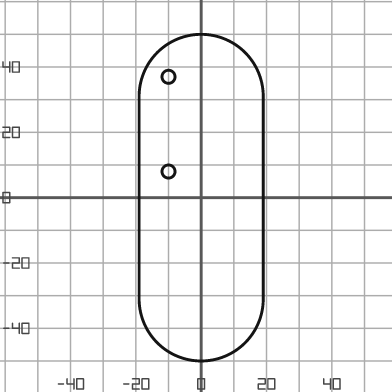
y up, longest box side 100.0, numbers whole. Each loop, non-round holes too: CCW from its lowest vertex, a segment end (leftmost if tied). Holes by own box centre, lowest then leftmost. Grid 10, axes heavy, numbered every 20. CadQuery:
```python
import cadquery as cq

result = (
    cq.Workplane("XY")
    .moveTo(-19.0, -31.0)
    .threePointArc((0.0, -50.0), (19.0, -31.0))
    .lineTo(19.0, 31.0)
    .threePointArc((0.0, 50.0), (-19.0, 31.0))
    .close()
    .moveTo(-10.0, 8.0)
    .circle(2.0)
    .moveTo(-10.0, 37.0)
    .circle(2.0)
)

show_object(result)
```